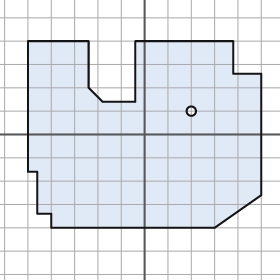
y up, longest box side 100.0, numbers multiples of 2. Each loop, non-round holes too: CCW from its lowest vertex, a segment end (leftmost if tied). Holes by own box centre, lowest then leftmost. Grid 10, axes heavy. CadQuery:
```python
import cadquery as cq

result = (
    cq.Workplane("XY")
    .moveTo(-40.0, -40.0)
    .lineTo(30.0, -40.0)
    .lineTo(50.0, -26.0)
    .lineTo(50.0, 26.0)
    .lineTo(38.0, 26.0)
    .lineTo(38.0, 40.0)
    .lineTo(-4.0, 40.0)
    .lineTo(-4.0, 14.0)
    .lineTo(-18.0, 14.0)
    .lineTo(-24.0, 20.0)
    .lineTo(-24.0, 40.0)
    .lineTo(-50.0, 40.0)
    .lineTo(-50.0, -16.0)
    .lineTo(-46.0, -16.0)
    .lineTo(-46.0, -34.0)
    .lineTo(-40.0, -34.0)
    .close()
    .moveTo(20.0, 10.0)
    .circle(2.0)
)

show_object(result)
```